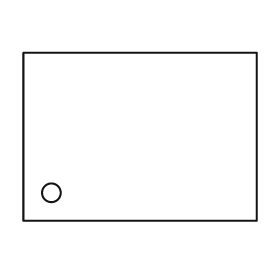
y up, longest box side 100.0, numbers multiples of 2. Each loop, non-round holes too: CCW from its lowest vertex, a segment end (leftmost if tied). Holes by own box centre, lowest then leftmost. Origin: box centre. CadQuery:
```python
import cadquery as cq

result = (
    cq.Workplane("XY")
    .moveTo(-50.0, -36.0)
    .lineTo(50.0, -36.0)
    .lineTo(50.0, 36.0)
    .lineTo(-50.0, 36.0)
    .close()
    .moveTo(-38.0, -24.0)
    .circle(4.0)
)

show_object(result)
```